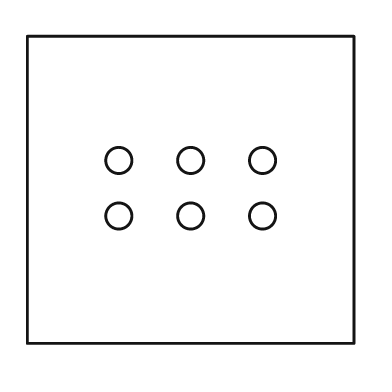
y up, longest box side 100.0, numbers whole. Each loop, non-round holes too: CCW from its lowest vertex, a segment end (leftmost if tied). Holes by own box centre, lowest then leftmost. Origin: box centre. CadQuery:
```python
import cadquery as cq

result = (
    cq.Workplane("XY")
    .moveTo(-50.0, -47.0)
    .lineTo(50.0, -47.0)
    .lineTo(50.0, 47.0)
    .lineTo(-50.0, 47.0)
    .close()
    .moveTo(-22.0, -8.0)
    .circle(4.0)
    .moveTo(0.0, -8.0)
    .circle(4.0)
    .moveTo(22.0, -8.0)
    .circle(4.0)
    .moveTo(-22.0, 9.0)
    .circle(4.0)
    .moveTo(0.0, 9.0)
    .circle(4.0)
    .moveTo(22.0, 9.0)
    .circle(4.0)
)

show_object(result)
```